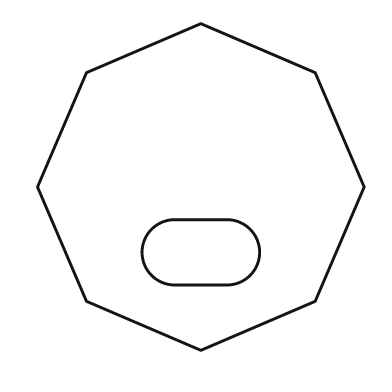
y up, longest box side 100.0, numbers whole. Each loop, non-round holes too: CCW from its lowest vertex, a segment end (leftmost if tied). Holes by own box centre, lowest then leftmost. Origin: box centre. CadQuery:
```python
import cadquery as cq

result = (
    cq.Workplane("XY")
    .moveTo(0.0, -50.0)
    .lineTo(35.0, -35.0)
    .lineTo(50.0, 0.0)
    .lineTo(35.0, 35.0)
    .lineTo(0.0, 50.0)
    .lineTo(-35.0, 35.0)
    .lineTo(-50.0, 0.0)
    .lineTo(-35.0, -35.0)
    .close()
    .moveTo(-8.0, -30.0)
    .lineTo(8.0, -30.0)
    .threePointArc((18.0, -20.0), (8.0, -10.0))
    .lineTo(-8.0, -10.0)
    .threePointArc((-18.0, -20.0), (-8.0, -30.0))
    .close()
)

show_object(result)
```